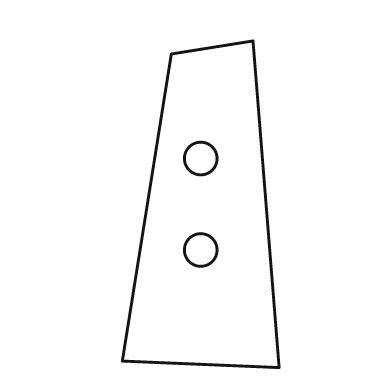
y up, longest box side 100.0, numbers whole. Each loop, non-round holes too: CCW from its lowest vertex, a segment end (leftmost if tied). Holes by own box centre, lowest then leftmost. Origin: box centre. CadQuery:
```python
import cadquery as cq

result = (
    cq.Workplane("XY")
    .moveTo(24.0, -50.0)
    .lineTo(16.0, 50.0)
    .lineTo(-9.0, 46.0)
    .lineTo(-24.0, -48.0)
    .close()
    .moveTo(0.0, -14.0)
    .circle(5.0)
    .moveTo(0.0, 14.0)
    .circle(5.0)
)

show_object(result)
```